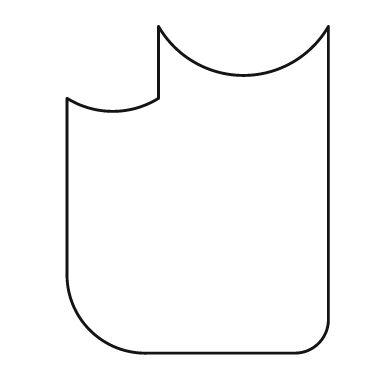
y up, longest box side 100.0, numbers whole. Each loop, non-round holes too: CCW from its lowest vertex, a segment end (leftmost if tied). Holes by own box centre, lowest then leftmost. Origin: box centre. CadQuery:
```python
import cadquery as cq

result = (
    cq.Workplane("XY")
    .moveTo(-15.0, -50.0)
    .lineTo(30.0, -50.0)
    .threePointArc((37.0, -47.0), (40.0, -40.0))
    .lineTo(40.0, 50.0)
    .threePointArc((14.0, 35.0), (-12.0, 50.0))
    .lineTo(-12.0, 28.0)
    .threePointArc((-26.0, 24.0), (-40.0, 28.0))
    .lineTo(-40.0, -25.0)
    .threePointArc((-33.0, -43.0), (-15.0, -50.0))
    .close()
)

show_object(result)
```